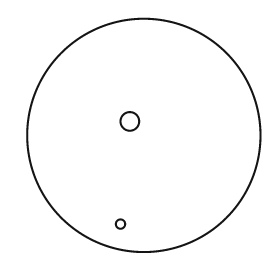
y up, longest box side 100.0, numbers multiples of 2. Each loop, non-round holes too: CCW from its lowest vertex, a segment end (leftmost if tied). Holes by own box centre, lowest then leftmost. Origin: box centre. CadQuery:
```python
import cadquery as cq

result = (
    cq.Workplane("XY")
    .moveTo(0.0, 0.0)
    .circle(50.0)
    .moveTo(-10.0, -38.0)
    .circle(2.0)
    .moveTo(-6.0, 6.0)
    .circle(4.0)
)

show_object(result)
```